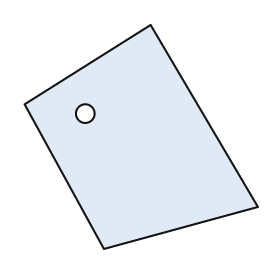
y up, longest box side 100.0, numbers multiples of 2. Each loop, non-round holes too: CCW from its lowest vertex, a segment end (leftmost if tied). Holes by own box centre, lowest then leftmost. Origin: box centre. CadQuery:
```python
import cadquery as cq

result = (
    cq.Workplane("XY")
    .moveTo(-16.0, -48.0)
    .lineTo(50.0, -30.0)
    .lineTo(4.0, 48.0)
    .lineTo(-50.0, 14.0)
    .close()
    .moveTo(-24.0, 10.0)
    .circle(4.0)
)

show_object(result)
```